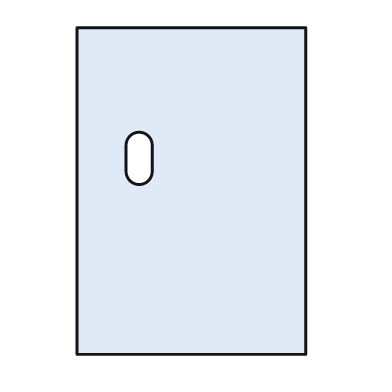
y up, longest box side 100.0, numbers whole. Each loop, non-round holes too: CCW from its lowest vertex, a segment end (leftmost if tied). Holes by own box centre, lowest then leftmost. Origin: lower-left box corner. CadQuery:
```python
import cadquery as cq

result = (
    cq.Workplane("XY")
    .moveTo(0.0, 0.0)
    .lineTo(70.0, 0.0)
    .lineTo(70.0, 100.0)
    .lineTo(0.0, 100.0)
    .close()
    .moveTo(15.0, 56.0)
    .threePointArc((19.0, 52.0), (23.0, 56.0))
    .lineTo(23.0, 64.0)
    .threePointArc((19.0, 68.0), (15.0, 64.0))
    .close()
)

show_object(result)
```